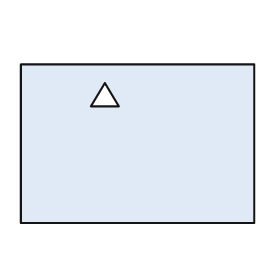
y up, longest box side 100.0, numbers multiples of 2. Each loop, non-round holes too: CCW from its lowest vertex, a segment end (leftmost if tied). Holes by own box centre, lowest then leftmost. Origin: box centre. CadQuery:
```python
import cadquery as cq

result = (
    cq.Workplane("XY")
    .moveTo(-50.0, -34.0)
    .lineTo(50.0, -34.0)
    .lineTo(50.0, 34.0)
    .lineTo(-50.0, 34.0)
    .close()
    .moveTo(-20.0, 16.0)
    .lineTo(-8.0, 16.0)
    .lineTo(-14.0, 26.0)
    .close()
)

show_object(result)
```